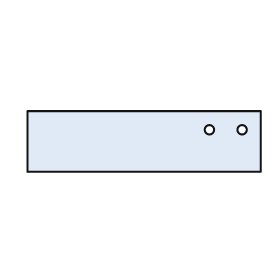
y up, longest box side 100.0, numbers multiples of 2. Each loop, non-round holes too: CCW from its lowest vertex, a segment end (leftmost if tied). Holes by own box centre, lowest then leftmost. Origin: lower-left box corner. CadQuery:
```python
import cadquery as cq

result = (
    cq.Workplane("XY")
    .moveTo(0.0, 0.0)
    .lineTo(100.0, 0.0)
    .lineTo(100.0, 26.0)
    .lineTo(0.0, 26.0)
    .close()
    .moveTo(78.0, 18.0)
    .circle(2.0)
    .moveTo(92.0, 18.0)
    .circle(2.0)
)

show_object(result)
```